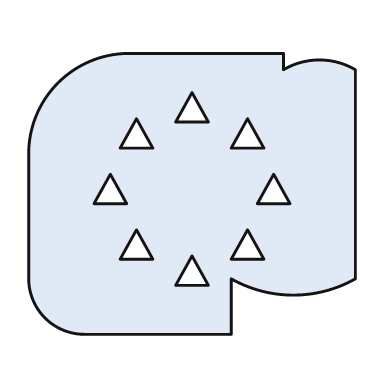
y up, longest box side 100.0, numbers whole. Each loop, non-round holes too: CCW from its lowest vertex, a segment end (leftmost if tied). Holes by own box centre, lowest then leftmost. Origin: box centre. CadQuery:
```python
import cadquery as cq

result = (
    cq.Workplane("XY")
    .moveTo(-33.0, -43.0)
    .lineTo(12.0, -43.0)
    .lineTo(12.0, -26.0)
    .threePointArc((31.0, -31.0), (50.0, -26.0))
    .lineTo(50.0, 38.0)
    .threePointArc((39.0, 41.0), (28.0, 38.0))
    .lineTo(28.0, 43.0)
    .lineTo(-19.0, 43.0)
    .threePointArc((-41.0, 34.0), (-50.0, 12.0))
    .lineTo(-50.0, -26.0)
    .threePointArc((-45.0, -38.0), (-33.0, -43.0))
    .close()
    .moveTo(-5.0, -28.0)
    .lineTo(5.0, -28.0)
    .lineTo(0.0, -19.0)
    .close()
    .moveTo(-22.0, -20.0)
    .lineTo(-12.0, -20.0)
    .lineTo(-17.0, -11.0)
    .close()
    .moveTo(12.0, -20.0)
    .lineTo(22.0, -20.0)
    .lineTo(17.0, -11.0)
    .close()
    .moveTo(-30.0, -3.0)
    .lineTo(-20.0, -3.0)
    .lineTo(-25.0, 6.0)
    .close()
    .moveTo(20.0, -3.0)
    .lineTo(30.0, -3.0)
    .lineTo(25.0, 6.0)
    .close()
    .moveTo(-22.0, 14.0)
    .lineTo(-12.0, 14.0)
    .lineTo(-17.0, 23.0)
    .close()
    .moveTo(12.0, 14.0)
    .lineTo(22.0, 14.0)
    .lineTo(17.0, 23.0)
    .close()
    .moveTo(-5.0, 22.0)
    .lineTo(5.0, 22.0)
    .lineTo(0.0, 31.0)
    .close()
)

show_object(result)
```